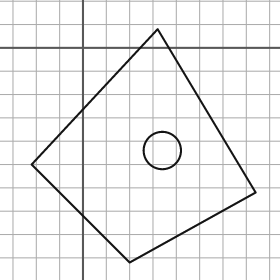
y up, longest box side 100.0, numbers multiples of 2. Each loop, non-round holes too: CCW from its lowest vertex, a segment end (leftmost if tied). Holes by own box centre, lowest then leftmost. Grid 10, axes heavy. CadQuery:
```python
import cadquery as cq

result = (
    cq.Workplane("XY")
    .moveTo(20.0, -92.0)
    .lineTo(74.0, -62.0)
    .lineTo(32.0, 8.0)
    .lineTo(-22.0, -50.0)
    .close()
    .moveTo(34.0, -44.0)
    .circle(8.0)
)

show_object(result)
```